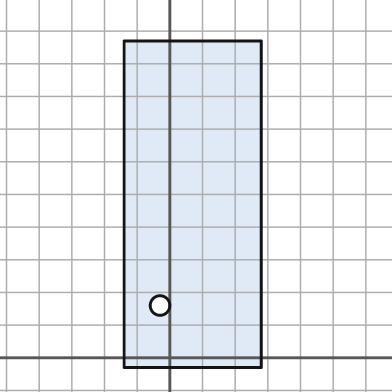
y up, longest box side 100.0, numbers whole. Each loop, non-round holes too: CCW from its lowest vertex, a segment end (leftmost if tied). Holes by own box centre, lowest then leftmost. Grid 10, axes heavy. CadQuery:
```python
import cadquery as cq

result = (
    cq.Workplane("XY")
    .moveTo(-14.0, -3.0)
    .lineTo(28.0, -3.0)
    .lineTo(28.0, 97.0)
    .lineTo(-14.0, 97.0)
    .close()
    .moveTo(-3.0, 16.0)
    .circle(3.0)
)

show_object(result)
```